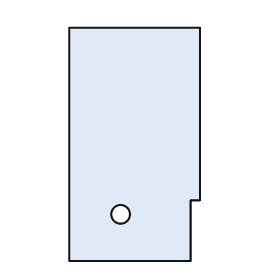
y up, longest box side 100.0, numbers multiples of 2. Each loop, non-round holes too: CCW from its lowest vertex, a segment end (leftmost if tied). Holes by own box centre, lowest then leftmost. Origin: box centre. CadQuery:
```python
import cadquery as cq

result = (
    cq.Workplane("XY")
    .moveTo(-28.0, -50.0)
    .lineTo(24.0, -50.0)
    .lineTo(24.0, -24.0)
    .lineTo(28.0, -24.0)
    .lineTo(28.0, 50.0)
    .lineTo(-28.0, 50.0)
    .close()
    .moveTo(-6.0, -30.0)
    .circle(4.0)
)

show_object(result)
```